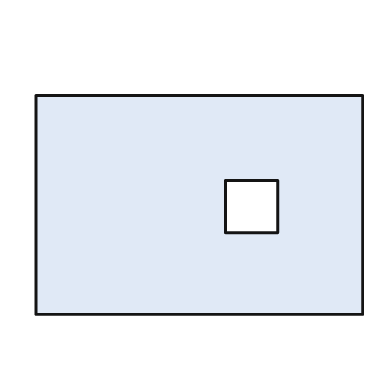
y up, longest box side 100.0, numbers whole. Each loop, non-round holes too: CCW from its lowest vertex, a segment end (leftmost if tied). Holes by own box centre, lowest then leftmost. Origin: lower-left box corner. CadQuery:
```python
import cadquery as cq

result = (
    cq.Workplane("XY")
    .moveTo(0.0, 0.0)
    .lineTo(100.0, 0.0)
    .lineTo(100.0, 67.0)
    .lineTo(0.0, 67.0)
    .close()
    .moveTo(58.0, 25.0)
    .lineTo(74.0, 25.0)
    .lineTo(74.0, 41.0)
    .lineTo(58.0, 41.0)
    .close()
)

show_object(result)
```